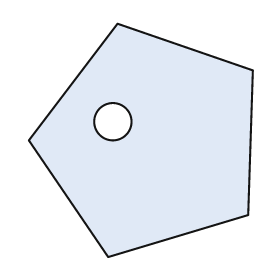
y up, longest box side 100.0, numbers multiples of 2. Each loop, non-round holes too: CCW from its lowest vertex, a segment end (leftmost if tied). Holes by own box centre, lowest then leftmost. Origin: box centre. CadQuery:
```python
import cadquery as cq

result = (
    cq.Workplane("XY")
    .moveTo(-14.0, -50.0)
    .lineTo(46.0, -32.0)
    .lineTo(48.0, 30.0)
    .lineTo(-10.0, 50.0)
    .lineTo(-48.0, 0.0)
    .close()
    .moveTo(-12.0, 8.0)
    .circle(8.0)
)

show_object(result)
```